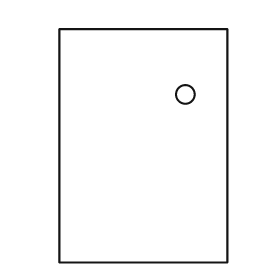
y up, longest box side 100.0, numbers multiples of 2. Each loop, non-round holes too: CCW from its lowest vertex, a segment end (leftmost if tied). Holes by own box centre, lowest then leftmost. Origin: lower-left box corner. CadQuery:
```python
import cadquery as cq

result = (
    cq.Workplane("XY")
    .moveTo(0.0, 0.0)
    .lineTo(72.0, 0.0)
    .lineTo(72.0, 100.0)
    .lineTo(0.0, 100.0)
    .close()
    .moveTo(54.0, 72.0)
    .circle(4.0)
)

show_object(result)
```